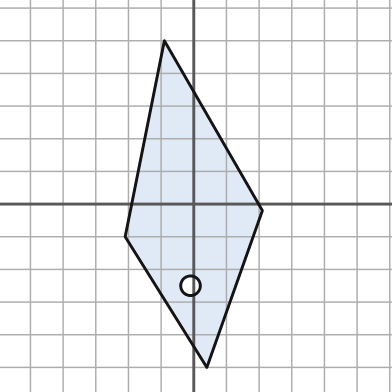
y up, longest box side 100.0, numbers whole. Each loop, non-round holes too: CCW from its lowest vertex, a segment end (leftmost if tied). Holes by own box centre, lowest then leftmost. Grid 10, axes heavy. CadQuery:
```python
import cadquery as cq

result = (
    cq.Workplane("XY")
    .moveTo(4.0, -50.0)
    .lineTo(21.0, -2.0)
    .lineTo(-9.0, 50.0)
    .lineTo(-21.0, -10.0)
    .close()
    .moveTo(-1.0, -25.0)
    .circle(3.0)
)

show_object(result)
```